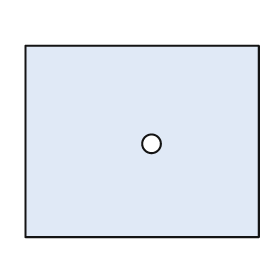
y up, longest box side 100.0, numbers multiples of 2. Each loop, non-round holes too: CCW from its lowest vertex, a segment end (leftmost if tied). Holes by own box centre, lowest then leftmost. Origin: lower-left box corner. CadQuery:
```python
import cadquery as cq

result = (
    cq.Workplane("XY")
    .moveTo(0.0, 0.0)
    .lineTo(100.0, 0.0)
    .lineTo(100.0, 82.0)
    .lineTo(0.0, 82.0)
    .close()
    .moveTo(54.0, 40.0)
    .circle(4.0)
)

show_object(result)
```